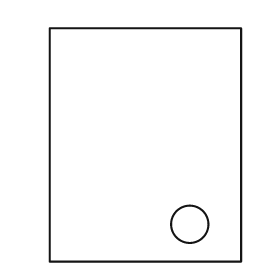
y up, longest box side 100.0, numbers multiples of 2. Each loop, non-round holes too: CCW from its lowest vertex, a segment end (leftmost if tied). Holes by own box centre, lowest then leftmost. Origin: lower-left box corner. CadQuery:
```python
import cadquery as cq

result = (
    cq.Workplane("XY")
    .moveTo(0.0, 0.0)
    .lineTo(82.0, 0.0)
    .lineTo(82.0, 100.0)
    .lineTo(0.0, 100.0)
    .close()
    .moveTo(60.0, 16.0)
    .circle(8.0)
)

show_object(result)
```